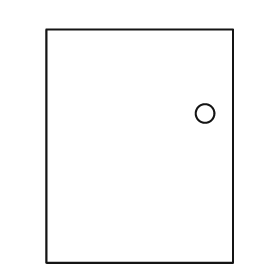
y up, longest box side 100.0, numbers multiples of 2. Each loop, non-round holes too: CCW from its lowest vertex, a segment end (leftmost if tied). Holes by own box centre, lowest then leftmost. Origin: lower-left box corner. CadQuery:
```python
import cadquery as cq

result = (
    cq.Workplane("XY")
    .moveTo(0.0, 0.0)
    .lineTo(80.0, 0.0)
    .lineTo(80.0, 100.0)
    .lineTo(0.0, 100.0)
    .close()
    .moveTo(68.0, 64.0)
    .circle(4.0)
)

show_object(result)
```